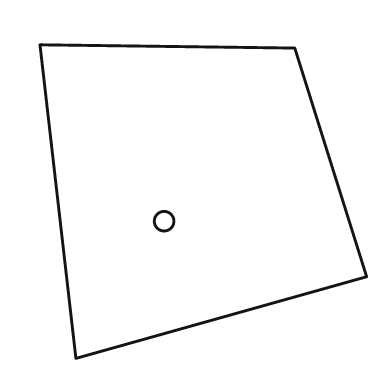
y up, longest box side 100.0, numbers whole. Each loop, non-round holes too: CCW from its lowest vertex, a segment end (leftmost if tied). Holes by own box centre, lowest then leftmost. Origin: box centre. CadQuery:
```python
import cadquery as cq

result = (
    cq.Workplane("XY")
    .moveTo(-39.0, -48.0)
    .lineTo(50.0, -23.0)
    .lineTo(28.0, 47.0)
    .lineTo(-50.0, 48.0)
    .close()
    .moveTo(-12.0, -6.0)
    .circle(3.0)
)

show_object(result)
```